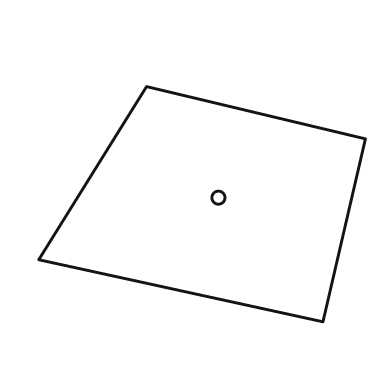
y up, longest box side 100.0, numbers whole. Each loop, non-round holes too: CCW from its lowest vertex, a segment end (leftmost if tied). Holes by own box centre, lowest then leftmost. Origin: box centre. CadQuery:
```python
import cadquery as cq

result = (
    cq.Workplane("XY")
    .moveTo(37.0, -36.0)
    .lineTo(50.0, 20.0)
    .lineTo(-17.0, 36.0)
    .lineTo(-50.0, -17.0)
    .close()
    .moveTo(5.0, 2.0)
    .circle(2.0)
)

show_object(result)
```